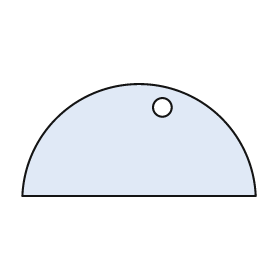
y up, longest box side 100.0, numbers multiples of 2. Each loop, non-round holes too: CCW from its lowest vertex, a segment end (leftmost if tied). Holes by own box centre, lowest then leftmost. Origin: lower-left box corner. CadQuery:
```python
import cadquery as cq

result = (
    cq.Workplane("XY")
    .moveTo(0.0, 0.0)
    .lineTo(100.0, 0.0)
    .threePointArc((50.0, 48.0), (0.0, 0.0))
    .close()
    .moveTo(60.0, 38.0)
    .circle(4.0)
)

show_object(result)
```